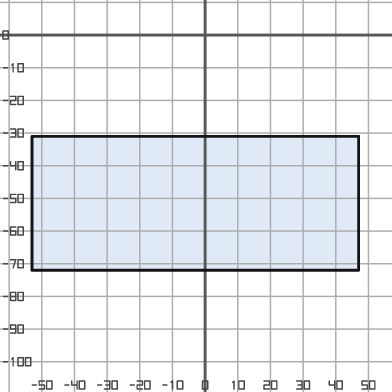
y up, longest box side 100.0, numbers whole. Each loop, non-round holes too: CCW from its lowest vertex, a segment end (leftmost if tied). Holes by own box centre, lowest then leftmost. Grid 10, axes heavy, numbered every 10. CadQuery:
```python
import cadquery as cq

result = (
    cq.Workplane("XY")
    .moveTo(-53.0, -72.0)
    .lineTo(47.0, -72.0)
    .lineTo(47.0, -31.0)
    .lineTo(-53.0, -31.0)
    .close()
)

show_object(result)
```